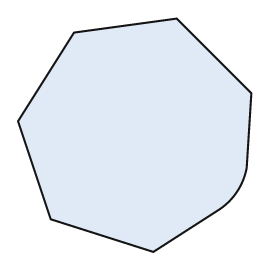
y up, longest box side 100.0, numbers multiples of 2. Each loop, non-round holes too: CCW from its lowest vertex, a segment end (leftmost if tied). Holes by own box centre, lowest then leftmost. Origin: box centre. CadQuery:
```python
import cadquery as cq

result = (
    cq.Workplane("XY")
    .moveTo(8.0, -50.0)
    .lineTo(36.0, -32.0)
    .threePointArc((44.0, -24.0), (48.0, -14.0))
    .lineTo(50.0, 18.0)
    .lineTo(18.0, 50.0)
    .lineTo(-26.0, 44.0)
    .lineTo(-50.0, 6.0)
    .lineTo(-36.0, -36.0)
    .close()
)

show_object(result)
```